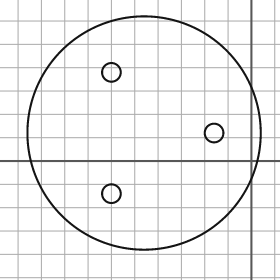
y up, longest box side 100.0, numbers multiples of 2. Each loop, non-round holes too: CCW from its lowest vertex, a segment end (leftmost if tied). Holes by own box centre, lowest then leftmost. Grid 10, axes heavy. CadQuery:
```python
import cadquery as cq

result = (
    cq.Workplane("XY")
    .moveTo(-46.0, 12.0)
    .circle(50.0)
    .moveTo(-60.0, -14.0)
    .circle(4.0)
    .moveTo(-16.0, 12.0)
    .circle(4.0)
    .moveTo(-60.0, 38.0)
    .circle(4.0)
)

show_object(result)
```